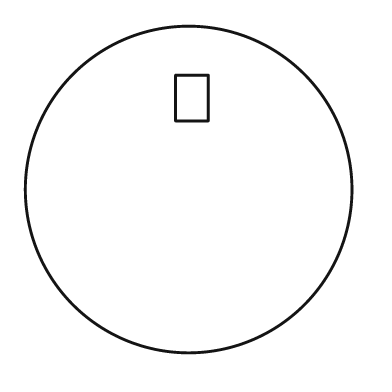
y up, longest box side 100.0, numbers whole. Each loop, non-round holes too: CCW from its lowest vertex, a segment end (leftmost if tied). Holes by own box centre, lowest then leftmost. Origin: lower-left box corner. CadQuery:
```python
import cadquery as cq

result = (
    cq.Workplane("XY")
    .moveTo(50.0, 50.0)
    .circle(50.0)
    .moveTo(46.0, 71.0)
    .lineTo(56.0, 71.0)
    .lineTo(56.0, 85.0)
    .lineTo(46.0, 85.0)
    .close()
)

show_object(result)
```